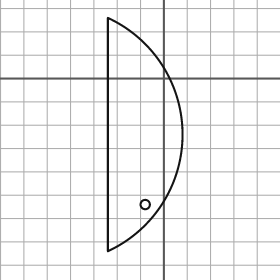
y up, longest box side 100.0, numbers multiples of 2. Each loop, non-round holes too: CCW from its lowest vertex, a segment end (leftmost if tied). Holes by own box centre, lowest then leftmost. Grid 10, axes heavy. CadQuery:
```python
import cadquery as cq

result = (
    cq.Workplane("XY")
    .moveTo(-24.0, -74.0)
    .threePointArc((8.0, -24.0), (-24.0, 26.0))
    .close()
    .moveTo(-8.0, -54.0)
    .circle(2.0)
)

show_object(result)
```